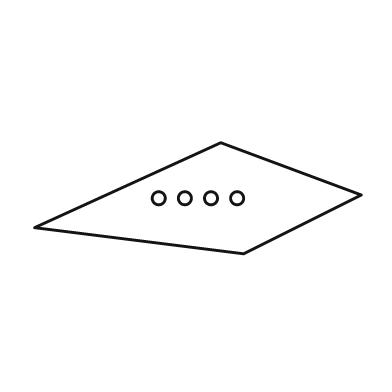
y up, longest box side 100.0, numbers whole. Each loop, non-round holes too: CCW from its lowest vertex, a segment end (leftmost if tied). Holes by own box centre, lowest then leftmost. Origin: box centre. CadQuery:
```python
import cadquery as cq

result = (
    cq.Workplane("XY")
    .moveTo(14.0, -17.0)
    .lineTo(50.0, 1.0)
    .lineTo(7.0, 17.0)
    .lineTo(-50.0, -9.0)
    .close()
    .moveTo(-12.0, 0.0)
    .circle(2.0)
    .moveTo(-4.0, 0.0)
    .circle(2.0)
    .moveTo(4.0, 0.0)
    .circle(2.0)
    .moveTo(12.0, 0.0)
    .circle(2.0)
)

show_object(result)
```